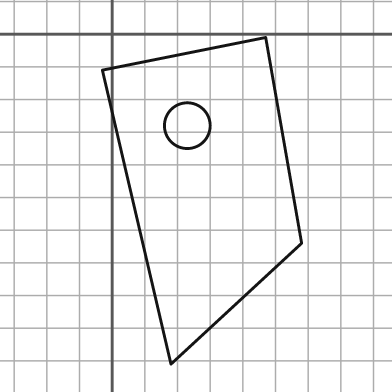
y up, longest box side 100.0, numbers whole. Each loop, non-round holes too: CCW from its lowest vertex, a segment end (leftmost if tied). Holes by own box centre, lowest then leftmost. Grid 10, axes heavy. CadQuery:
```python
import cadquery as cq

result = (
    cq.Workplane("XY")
    .moveTo(18.0, -101.0)
    .lineTo(58.0, -64.0)
    .lineTo(47.0, -1.0)
    .lineTo(-3.0, -11.0)
    .close()
    .moveTo(23.0, -28.0)
    .circle(7.0)
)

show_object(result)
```